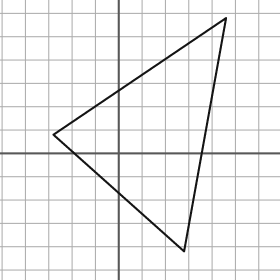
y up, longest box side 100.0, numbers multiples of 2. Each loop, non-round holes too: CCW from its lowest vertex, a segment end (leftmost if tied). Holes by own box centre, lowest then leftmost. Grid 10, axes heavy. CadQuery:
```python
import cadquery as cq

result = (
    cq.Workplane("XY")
    .moveTo(28.0, -42.0)
    .lineTo(46.0, 58.0)
    .lineTo(-28.0, 8.0)
    .close()
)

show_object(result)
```